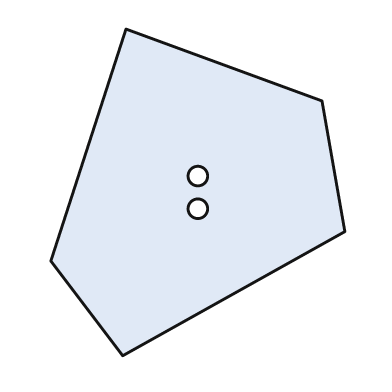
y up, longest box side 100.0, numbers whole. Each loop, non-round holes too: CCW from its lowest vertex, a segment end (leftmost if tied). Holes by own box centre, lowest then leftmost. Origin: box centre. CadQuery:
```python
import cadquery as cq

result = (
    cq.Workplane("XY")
    .moveTo(-23.0, -50.0)
    .lineTo(45.0, -12.0)
    .lineTo(38.0, 28.0)
    .lineTo(-22.0, 50.0)
    .lineTo(-45.0, -21.0)
    .close()
    .moveTo(0.0, -5.0)
    .circle(3.0)
    .moveTo(0.0, 5.0)
    .circle(3.0)
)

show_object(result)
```